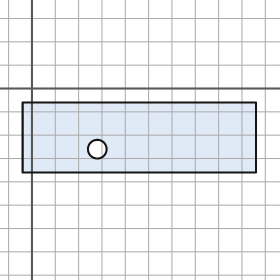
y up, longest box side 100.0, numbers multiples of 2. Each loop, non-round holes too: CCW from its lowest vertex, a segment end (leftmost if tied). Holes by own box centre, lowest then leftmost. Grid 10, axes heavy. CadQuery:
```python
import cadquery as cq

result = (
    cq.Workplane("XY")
    .moveTo(-4.0, -36.0)
    .lineTo(96.0, -36.0)
    .lineTo(96.0, -6.0)
    .lineTo(-4.0, -6.0)
    .close()
    .moveTo(28.0, -26.0)
    .circle(4.0)
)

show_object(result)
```